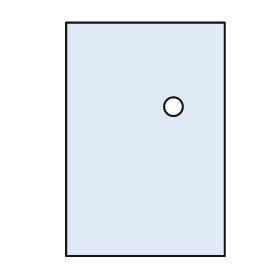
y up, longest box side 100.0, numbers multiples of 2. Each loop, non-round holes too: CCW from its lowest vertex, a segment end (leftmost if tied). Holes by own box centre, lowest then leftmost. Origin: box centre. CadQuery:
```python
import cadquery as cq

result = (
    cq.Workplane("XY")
    .moveTo(-34.0, -50.0)
    .lineTo(34.0, -50.0)
    .lineTo(34.0, 50.0)
    .lineTo(-34.0, 50.0)
    .close()
    .moveTo(12.0, 14.0)
    .circle(4.0)
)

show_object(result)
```